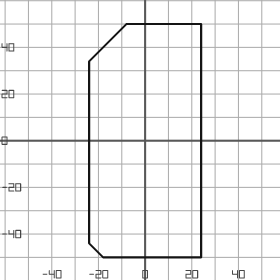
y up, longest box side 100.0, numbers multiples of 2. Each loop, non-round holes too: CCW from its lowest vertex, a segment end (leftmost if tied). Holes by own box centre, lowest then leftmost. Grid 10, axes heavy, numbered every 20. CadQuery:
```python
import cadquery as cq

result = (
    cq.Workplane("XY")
    .moveTo(-18.0, -50.0)
    .lineTo(24.0, -50.0)
    .lineTo(24.0, 50.0)
    .lineTo(-8.0, 50.0)
    .lineTo(-24.0, 34.0)
    .lineTo(-24.0, -44.0)
    .close()
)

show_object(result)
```